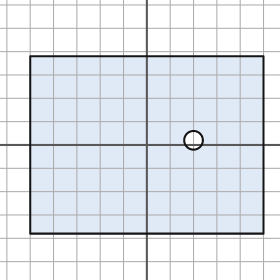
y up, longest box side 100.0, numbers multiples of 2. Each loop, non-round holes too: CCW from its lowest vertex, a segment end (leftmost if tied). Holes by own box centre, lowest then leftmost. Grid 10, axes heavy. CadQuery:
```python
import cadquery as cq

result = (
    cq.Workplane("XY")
    .moveTo(-50.0, -38.0)
    .lineTo(50.0, -38.0)
    .lineTo(50.0, 38.0)
    .lineTo(-50.0, 38.0)
    .close()
    .moveTo(20.0, 2.0)
    .circle(4.0)
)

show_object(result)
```